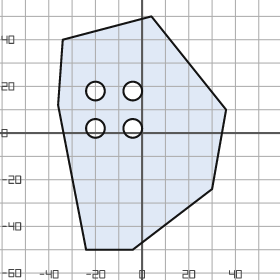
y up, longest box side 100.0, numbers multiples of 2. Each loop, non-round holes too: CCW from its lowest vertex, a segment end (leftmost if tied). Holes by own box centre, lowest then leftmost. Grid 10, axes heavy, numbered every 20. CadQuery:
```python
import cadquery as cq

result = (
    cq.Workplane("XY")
    .moveTo(-24.0, -50.0)
    .lineTo(-4.0, -50.0)
    .lineTo(30.0, -24.0)
    .lineTo(36.0, 10.0)
    .lineTo(4.0, 50.0)
    .lineTo(-34.0, 40.0)
    .lineTo(-36.0, 12.0)
    .close()
    .moveTo(-20.0, 2.0)
    .circle(4.0)
    .moveTo(-4.0, 2.0)
    .circle(4.0)
    .moveTo(-20.0, 18.0)
    .circle(4.0)
    .moveTo(-4.0, 18.0)
    .circle(4.0)
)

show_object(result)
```